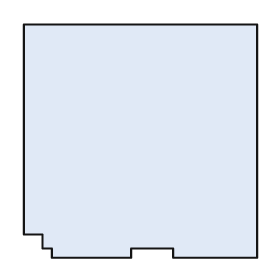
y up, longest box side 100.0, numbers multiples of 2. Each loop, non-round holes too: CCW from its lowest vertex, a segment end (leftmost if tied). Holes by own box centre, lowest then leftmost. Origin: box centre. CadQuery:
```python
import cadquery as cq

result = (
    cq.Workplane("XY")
    .moveTo(-38.0, -50.0)
    .lineTo(-4.0, -50.0)
    .lineTo(-4.0, -46.0)
    .lineTo(14.0, -46.0)
    .lineTo(14.0, -50.0)
    .lineTo(50.0, -50.0)
    .lineTo(50.0, 50.0)
    .lineTo(-50.0, 50.0)
    .lineTo(-50.0, -40.0)
    .lineTo(-42.0, -40.0)
    .lineTo(-42.0, -46.0)
    .lineTo(-38.0, -46.0)
    .close()
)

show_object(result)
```